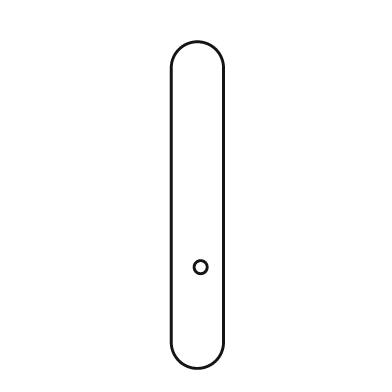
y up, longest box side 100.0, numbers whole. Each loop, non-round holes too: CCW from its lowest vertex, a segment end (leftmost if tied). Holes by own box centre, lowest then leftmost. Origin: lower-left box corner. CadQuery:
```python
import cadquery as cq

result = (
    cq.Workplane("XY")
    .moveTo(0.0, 8.0)
    .threePointArc((8.0, 0.0), (16.0, 8.0))
    .lineTo(16.0, 92.0)
    .threePointArc((8.0, 100.0), (0.0, 92.0))
    .close()
    .moveTo(9.0, 31.0)
    .circle(2.0)
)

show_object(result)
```